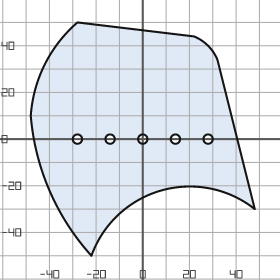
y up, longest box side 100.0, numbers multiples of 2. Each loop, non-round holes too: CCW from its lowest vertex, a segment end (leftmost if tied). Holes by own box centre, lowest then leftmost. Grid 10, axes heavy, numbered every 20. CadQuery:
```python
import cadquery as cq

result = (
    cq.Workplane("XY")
    .moveTo(-22.0, -50.0)
    .threePointArc((8.0, -22.0), (48.0, -30.0))
    .lineTo(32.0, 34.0)
    .threePointArc((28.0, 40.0), (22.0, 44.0))
    .lineTo(-28.0, 50.0)
    .threePointArc((-42.0, 32.0), (-48.0, 10.0))
    .threePointArc((-40.0, -22.0), (-22.0, -50.0))
    .close()
    .moveTo(-28.0, 0.0)
    .circle(2.0)
    .moveTo(-14.0, 0.0)
    .circle(2.0)
    .moveTo(0.0, 0.0)
    .circle(2.0)
    .moveTo(14.0, 0.0)
    .circle(2.0)
    .moveTo(28.0, 0.0)
    .circle(2.0)
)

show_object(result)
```